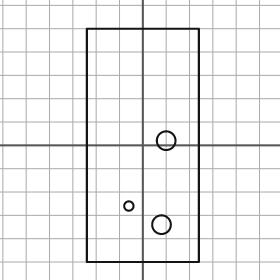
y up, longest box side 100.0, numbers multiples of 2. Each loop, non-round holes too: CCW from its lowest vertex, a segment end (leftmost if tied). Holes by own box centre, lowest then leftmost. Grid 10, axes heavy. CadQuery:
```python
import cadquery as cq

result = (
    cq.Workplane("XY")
    .moveTo(-24.0, -50.0)
    .lineTo(24.0, -50.0)
    .lineTo(24.0, 50.0)
    .lineTo(-24.0, 50.0)
    .close()
    .moveTo(8.0, -34.0)
    .circle(4.0)
    .moveTo(-6.0, -26.0)
    .circle(2.0)
    .moveTo(10.0, 2.0)
    .circle(4.0)
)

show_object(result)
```